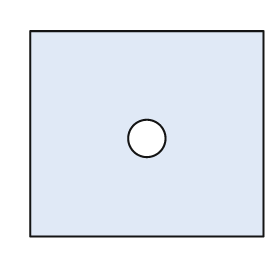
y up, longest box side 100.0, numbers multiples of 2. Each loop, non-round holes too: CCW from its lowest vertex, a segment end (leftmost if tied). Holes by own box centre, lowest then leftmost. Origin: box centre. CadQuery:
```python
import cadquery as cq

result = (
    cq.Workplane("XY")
    .moveTo(-50.0, -44.0)
    .lineTo(50.0, -44.0)
    .lineTo(50.0, 44.0)
    .lineTo(-50.0, 44.0)
    .close()
    .moveTo(0.0, -2.0)
    .circle(8.0)
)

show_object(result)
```